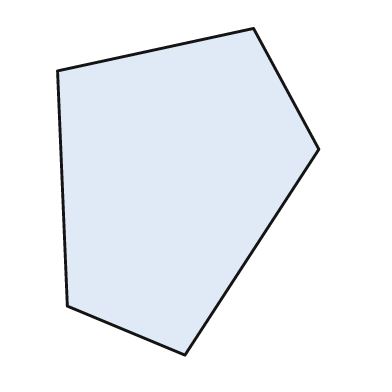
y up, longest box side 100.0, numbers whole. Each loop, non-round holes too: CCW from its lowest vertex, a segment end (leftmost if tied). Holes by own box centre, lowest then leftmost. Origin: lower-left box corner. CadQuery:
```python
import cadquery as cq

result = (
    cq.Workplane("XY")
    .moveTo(39.0, 0.0)
    .lineTo(80.0, 63.0)
    .lineTo(60.0, 100.0)
    .lineTo(0.0, 87.0)
    .lineTo(3.0, 15.0)
    .close()
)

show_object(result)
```